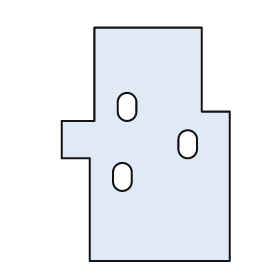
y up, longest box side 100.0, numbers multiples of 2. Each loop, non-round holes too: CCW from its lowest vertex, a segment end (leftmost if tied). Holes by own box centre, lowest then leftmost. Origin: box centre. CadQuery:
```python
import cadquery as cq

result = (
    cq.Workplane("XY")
    .moveTo(-24.0, -50.0)
    .lineTo(36.0, -50.0)
    .lineTo(36.0, 14.0)
    .lineTo(24.0, 14.0)
    .lineTo(24.0, 50.0)
    .lineTo(-22.0, 50.0)
    .lineTo(-22.0, 10.0)
    .lineTo(-36.0, 10.0)
    .lineTo(-36.0, -6.0)
    .lineTo(-24.0, -6.0)
    .close()
    .moveTo(-14.0, -16.0)
    .threePointArc((-10.0, -20.0), (-6.0, -16.0))
    .lineTo(-6.0, -12.0)
    .threePointArc((-10.0, -8.0), (-14.0, -12.0))
    .close()
    .moveTo(14.0, -2.0)
    .threePointArc((18.0, -6.0), (22.0, -2.0))
    .lineTo(22.0, 2.0)
    .threePointArc((18.0, 6.0), (14.0, 2.0))
    .close()
    .moveTo(-12.0, 14.0)
    .threePointArc((-8.0, 10.0), (-4.0, 14.0))
    .lineTo(-4.0, 18.0)
    .threePointArc((-8.0, 22.0), (-12.0, 18.0))
    .close()
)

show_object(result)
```